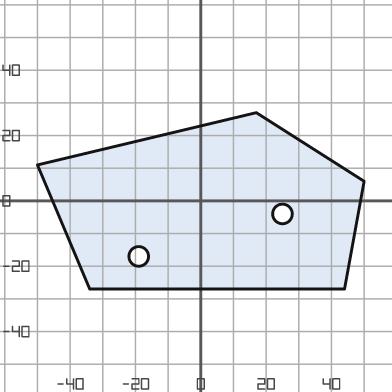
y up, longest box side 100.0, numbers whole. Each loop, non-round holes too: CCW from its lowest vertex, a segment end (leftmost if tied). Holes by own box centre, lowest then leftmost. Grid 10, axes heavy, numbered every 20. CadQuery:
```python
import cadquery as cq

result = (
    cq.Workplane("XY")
    .moveTo(-34.0, -27.0)
    .lineTo(44.0, -27.0)
    .lineTo(50.0, 6.0)
    .lineTo(17.0, 27.0)
    .lineTo(-50.0, 11.0)
    .close()
    .moveTo(-19.0, -17.0)
    .circle(3.0)
    .moveTo(25.0, -4.0)
    .circle(3.0)
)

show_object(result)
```